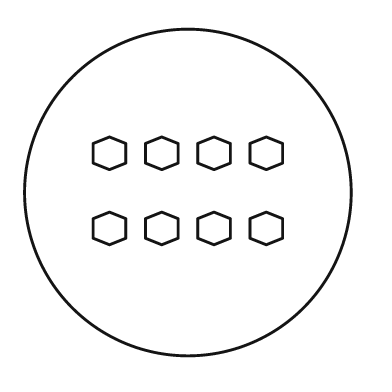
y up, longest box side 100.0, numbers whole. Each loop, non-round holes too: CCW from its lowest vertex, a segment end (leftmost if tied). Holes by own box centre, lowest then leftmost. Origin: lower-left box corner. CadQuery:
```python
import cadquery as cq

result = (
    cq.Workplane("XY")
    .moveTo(50.0, 50.0)
    .circle(50.0)
    .moveTo(26.0, 34.0)
    .lineTo(31.0, 36.0)
    .lineTo(31.0, 42.0)
    .lineTo(26.0, 44.0)
    .lineTo(21.0, 42.0)
    .lineTo(21.0, 36.0)
    .close()
    .moveTo(42.0, 34.0)
    .lineTo(47.0, 36.0)
    .lineTo(47.0, 42.0)
    .lineTo(42.0, 44.0)
    .lineTo(37.0, 42.0)
    .lineTo(37.0, 36.0)
    .close()
    .moveTo(58.0, 34.0)
    .lineTo(63.0, 36.0)
    .lineTo(63.0, 42.0)
    .lineTo(58.0, 44.0)
    .lineTo(53.0, 42.0)
    .lineTo(53.0, 36.0)
    .close()
    .moveTo(74.0, 34.0)
    .lineTo(79.0, 36.0)
    .lineTo(79.0, 42.0)
    .lineTo(74.0, 44.0)
    .lineTo(69.0, 42.0)
    .lineTo(69.0, 36.0)
    .close()
    .moveTo(26.0, 57.0)
    .lineTo(31.0, 59.0)
    .lineTo(31.0, 65.0)
    .lineTo(26.0, 67.0)
    .lineTo(21.0, 65.0)
    .lineTo(21.0, 59.0)
    .close()
    .moveTo(42.0, 57.0)
    .lineTo(47.0, 59.0)
    .lineTo(47.0, 65.0)
    .lineTo(42.0, 67.0)
    .lineTo(37.0, 65.0)
    .lineTo(37.0, 59.0)
    .close()
    .moveTo(58.0, 57.0)
    .lineTo(63.0, 59.0)
    .lineTo(63.0, 65.0)
    .lineTo(58.0, 67.0)
    .lineTo(53.0, 65.0)
    .lineTo(53.0, 59.0)
    .close()
    .moveTo(74.0, 57.0)
    .lineTo(79.0, 59.0)
    .lineTo(79.0, 65.0)
    .lineTo(74.0, 67.0)
    .lineTo(69.0, 65.0)
    .lineTo(69.0, 59.0)
    .close()
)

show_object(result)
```